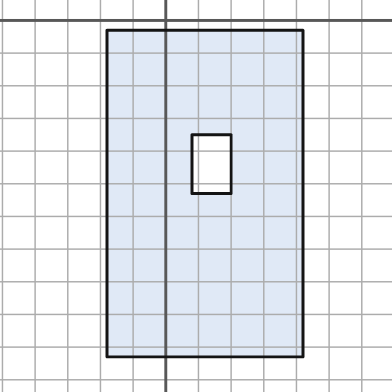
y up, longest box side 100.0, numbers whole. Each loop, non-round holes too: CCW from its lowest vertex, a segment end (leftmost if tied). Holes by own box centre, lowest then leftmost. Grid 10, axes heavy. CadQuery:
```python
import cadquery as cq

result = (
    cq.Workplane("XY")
    .moveTo(-18.0, -103.0)
    .lineTo(42.0, -103.0)
    .lineTo(42.0, -3.0)
    .lineTo(-18.0, -3.0)
    .close()
    .moveTo(8.0, -53.0)
    .lineTo(20.0, -53.0)
    .lineTo(20.0, -35.0)
    .lineTo(8.0, -35.0)
    .close()
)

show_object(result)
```